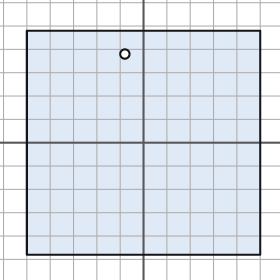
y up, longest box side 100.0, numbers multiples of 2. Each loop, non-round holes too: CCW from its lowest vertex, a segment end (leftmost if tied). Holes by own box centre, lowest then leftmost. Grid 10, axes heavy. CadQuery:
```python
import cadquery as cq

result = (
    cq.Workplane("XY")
    .moveTo(-50.0, -48.0)
    .lineTo(50.0, -48.0)
    .lineTo(50.0, 48.0)
    .lineTo(-50.0, 48.0)
    .close()
    .moveTo(-8.0, 38.0)
    .circle(2.0)
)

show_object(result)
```